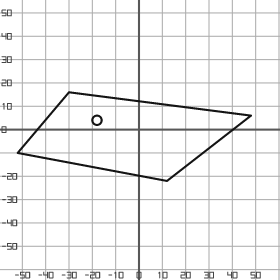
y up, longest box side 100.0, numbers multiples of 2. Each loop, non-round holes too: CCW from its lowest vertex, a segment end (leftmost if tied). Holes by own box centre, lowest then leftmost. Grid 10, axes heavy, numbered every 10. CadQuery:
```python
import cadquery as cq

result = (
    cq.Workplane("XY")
    .moveTo(12.0, -22.0)
    .lineTo(48.0, 6.0)
    .lineTo(-30.0, 16.0)
    .lineTo(-52.0, -10.0)
    .close()
    .moveTo(-18.0, 4.0)
    .circle(2.0)
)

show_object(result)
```